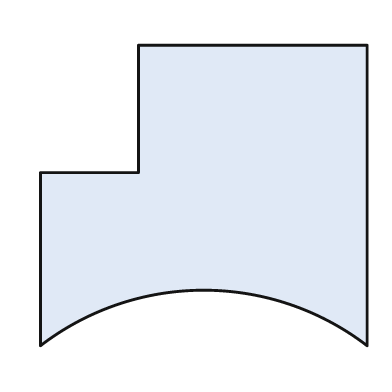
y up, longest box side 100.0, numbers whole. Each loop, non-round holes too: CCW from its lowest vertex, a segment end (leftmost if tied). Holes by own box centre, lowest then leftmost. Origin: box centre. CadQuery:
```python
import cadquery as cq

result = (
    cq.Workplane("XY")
    .moveTo(-50.0, -46.0)
    .threePointArc((0.0, -29.0), (50.0, -46.0))
    .lineTo(50.0, 46.0)
    .lineTo(-20.0, 46.0)
    .lineTo(-20.0, 7.0)
    .lineTo(-50.0, 7.0)
    .close()
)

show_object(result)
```